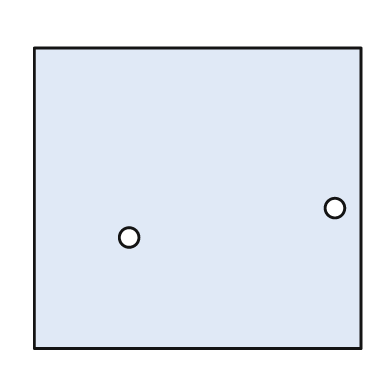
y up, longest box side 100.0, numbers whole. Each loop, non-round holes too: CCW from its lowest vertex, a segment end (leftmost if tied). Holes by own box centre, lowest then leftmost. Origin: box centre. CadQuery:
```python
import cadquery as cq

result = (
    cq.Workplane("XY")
    .moveTo(-50.0, -46.0)
    .lineTo(50.0, -46.0)
    .lineTo(50.0, 46.0)
    .lineTo(-50.0, 46.0)
    .close()
    .moveTo(-21.0, -12.0)
    .circle(3.0)
    .moveTo(42.0, -3.0)
    .circle(3.0)
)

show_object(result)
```